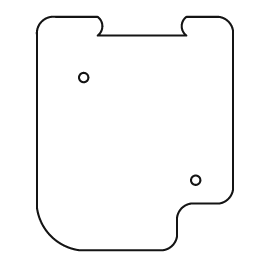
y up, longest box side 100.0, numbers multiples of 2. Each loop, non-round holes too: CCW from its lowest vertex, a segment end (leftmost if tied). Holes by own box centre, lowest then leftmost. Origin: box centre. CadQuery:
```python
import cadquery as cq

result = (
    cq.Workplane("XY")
    .moveTo(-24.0, -50.0)
    .lineTo(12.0, -50.0)
    .threePointArc((16.0, -48.0), (18.0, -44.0))
    .lineTo(18.0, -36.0)
    .threePointArc((20.0, -32.0), (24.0, -30.0))
    .lineTo(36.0, -30.0)
    .threePointArc((40.0, -28.0), (42.0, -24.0))
    .lineTo(42.0, 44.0)
    .threePointArc((40.0, 48.0), (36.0, 50.0))
    .lineTo(22.0, 50.0)
    .threePointArc((20.0, 46.0), (22.0, 42.0))
    .lineTo(-16.0, 42.0)
    .threePointArc((-14.0, 46.0), (-16.0, 50.0))
    .lineTo(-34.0, 50.0)
    .threePointArc((-40.0, 48.0), (-42.0, 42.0))
    .lineTo(-42.0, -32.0)
    .threePointArc((-36.0, -44.0), (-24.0, -50.0))
    .close()
    .moveTo(26.0, -20.0)
    .circle(2.0)
    .moveTo(-22.0, 24.0)
    .circle(2.0)
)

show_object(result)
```